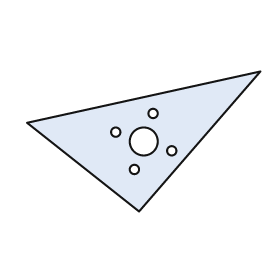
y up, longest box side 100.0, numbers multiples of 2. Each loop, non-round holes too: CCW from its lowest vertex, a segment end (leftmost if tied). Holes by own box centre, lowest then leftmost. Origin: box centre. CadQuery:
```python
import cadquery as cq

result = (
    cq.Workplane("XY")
    .moveTo(-2.0, -30.0)
    .lineTo(50.0, 30.0)
    .lineTo(-50.0, 8.0)
    .close()
    .moveTo(-4.0, -12.0)
    .circle(2.0)
    .moveTo(12.0, -4.0)
    .circle(2.0)
    .moveTo(0.0, 0.0)
    .circle(6.0)
    .moveTo(-12.0, 4.0)
    .circle(2.0)
    .moveTo(4.0, 12.0)
    .circle(2.0)
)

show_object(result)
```